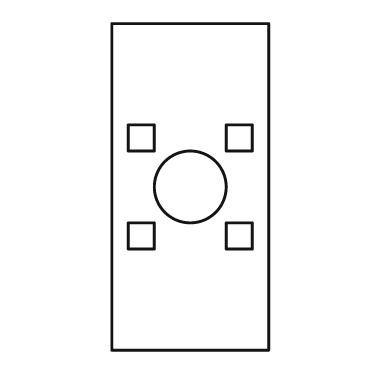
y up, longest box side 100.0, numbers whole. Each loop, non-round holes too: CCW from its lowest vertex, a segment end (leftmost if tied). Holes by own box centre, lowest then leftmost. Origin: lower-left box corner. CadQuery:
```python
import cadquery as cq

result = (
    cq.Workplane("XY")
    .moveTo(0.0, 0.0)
    .lineTo(48.0, 0.0)
    .lineTo(48.0, 100.0)
    .lineTo(0.0, 100.0)
    .close()
    .moveTo(5.0, 31.0)
    .lineTo(13.0, 31.0)
    .lineTo(13.0, 39.0)
    .lineTo(5.0, 39.0)
    .close()
    .moveTo(35.0, 31.0)
    .lineTo(43.0, 31.0)
    .lineTo(43.0, 39.0)
    .lineTo(35.0, 39.0)
    .close()
    .moveTo(24.0, 50.0)
    .circle(11.0)
    .moveTo(5.0, 61.0)
    .lineTo(13.0, 61.0)
    .lineTo(13.0, 69.0)
    .lineTo(5.0, 69.0)
    .close()
    .moveTo(35.0, 61.0)
    .lineTo(43.0, 61.0)
    .lineTo(43.0, 69.0)
    .lineTo(35.0, 69.0)
    .close()
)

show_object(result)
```